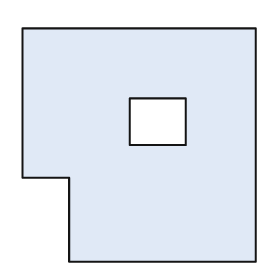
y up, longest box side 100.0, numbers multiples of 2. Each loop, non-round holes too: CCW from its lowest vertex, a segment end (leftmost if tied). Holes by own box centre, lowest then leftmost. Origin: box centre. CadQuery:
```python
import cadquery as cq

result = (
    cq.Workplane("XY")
    .moveTo(-30.0, -50.0)
    .lineTo(50.0, -50.0)
    .lineTo(50.0, 50.0)
    .lineTo(-50.0, 50.0)
    .lineTo(-50.0, -14.0)
    .lineTo(-30.0, -14.0)
    .close()
    .moveTo(-4.0, 0.0)
    .lineTo(20.0, 0.0)
    .lineTo(20.0, 20.0)
    .lineTo(-4.0, 20.0)
    .close()
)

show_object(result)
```